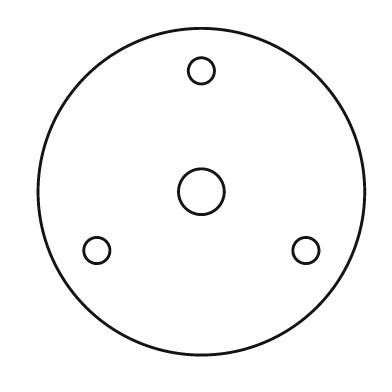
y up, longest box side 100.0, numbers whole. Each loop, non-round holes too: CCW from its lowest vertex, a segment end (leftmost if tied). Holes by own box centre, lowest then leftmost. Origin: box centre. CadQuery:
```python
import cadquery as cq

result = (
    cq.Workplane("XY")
    .moveTo(0.0, 0.0)
    .circle(50.0)
    .moveTo(-32.0, -18.0)
    .circle(4.0)
    .moveTo(32.0, -18.0)
    .circle(4.0)
    .moveTo(0.0, 0.0)
    .circle(7.0)
    .moveTo(0.0, 37.0)
    .circle(4.0)
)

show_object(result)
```